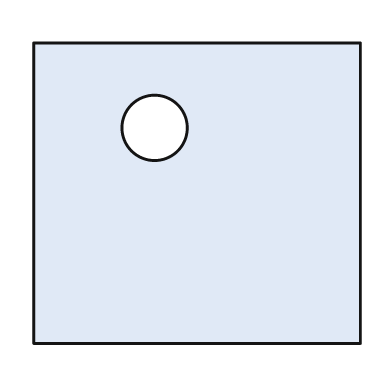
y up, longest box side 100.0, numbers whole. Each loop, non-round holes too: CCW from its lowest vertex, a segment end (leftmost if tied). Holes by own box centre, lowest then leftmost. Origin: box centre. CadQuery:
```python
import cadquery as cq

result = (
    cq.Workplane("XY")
    .moveTo(-50.0, -46.0)
    .lineTo(50.0, -46.0)
    .lineTo(50.0, 46.0)
    .lineTo(-50.0, 46.0)
    .close()
    .moveTo(-13.0, 20.0)
    .circle(10.0)
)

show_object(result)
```